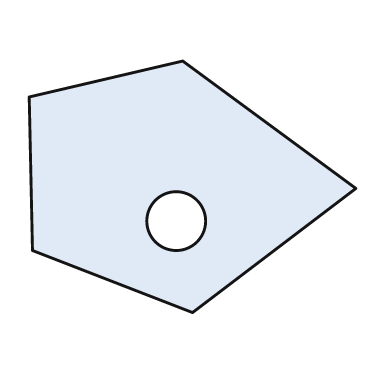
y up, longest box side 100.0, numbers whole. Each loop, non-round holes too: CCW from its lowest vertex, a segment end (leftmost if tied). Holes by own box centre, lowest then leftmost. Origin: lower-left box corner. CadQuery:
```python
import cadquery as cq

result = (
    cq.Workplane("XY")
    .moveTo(50.0, 0.0)
    .lineTo(100.0, 38.0)
    .lineTo(47.0, 77.0)
    .lineTo(0.0, 66.0)
    .lineTo(1.0, 19.0)
    .close()
    .moveTo(45.0, 28.0)
    .circle(9.0)
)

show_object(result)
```